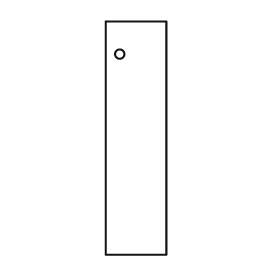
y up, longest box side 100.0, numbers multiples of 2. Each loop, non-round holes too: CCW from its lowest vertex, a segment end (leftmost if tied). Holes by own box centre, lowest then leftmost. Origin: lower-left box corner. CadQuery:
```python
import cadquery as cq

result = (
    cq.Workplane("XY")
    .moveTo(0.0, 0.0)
    .lineTo(26.0, 0.0)
    .lineTo(26.0, 100.0)
    .lineTo(0.0, 100.0)
    .close()
    .moveTo(6.0, 86.0)
    .circle(2.0)
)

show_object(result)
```